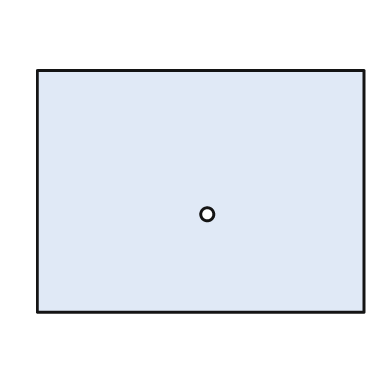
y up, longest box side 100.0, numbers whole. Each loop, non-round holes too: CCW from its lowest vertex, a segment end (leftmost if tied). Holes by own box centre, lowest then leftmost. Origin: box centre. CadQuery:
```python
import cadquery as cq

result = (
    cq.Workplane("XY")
    .moveTo(-50.0, -37.0)
    .lineTo(50.0, -37.0)
    .lineTo(50.0, 37.0)
    .lineTo(-50.0, 37.0)
    .close()
    .moveTo(2.0, -7.0)
    .circle(2.0)
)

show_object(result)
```